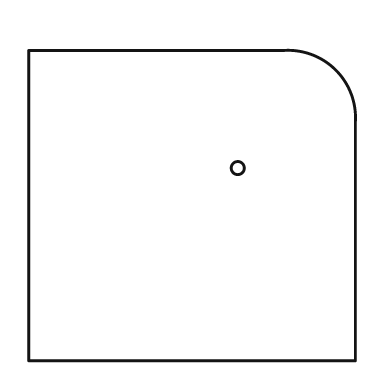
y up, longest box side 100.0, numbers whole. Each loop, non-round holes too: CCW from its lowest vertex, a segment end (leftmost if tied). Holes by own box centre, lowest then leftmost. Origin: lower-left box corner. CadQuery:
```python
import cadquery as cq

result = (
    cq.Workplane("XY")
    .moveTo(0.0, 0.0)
    .lineTo(100.0, 0.0)
    .lineTo(100.0, 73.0)
    .threePointArc((94.0, 89.0), (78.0, 95.0))
    .lineTo(0.0, 95.0)
    .close()
    .moveTo(64.0, 59.0)
    .circle(2.0)
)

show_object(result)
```